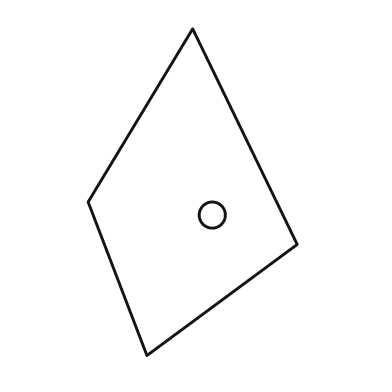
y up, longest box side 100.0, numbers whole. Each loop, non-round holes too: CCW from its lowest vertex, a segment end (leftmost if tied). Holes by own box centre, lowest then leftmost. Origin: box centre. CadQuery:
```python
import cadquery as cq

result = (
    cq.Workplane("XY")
    .moveTo(-14.0, -50.0)
    .lineTo(32.0, -16.0)
    .lineTo(0.0, 50.0)
    .lineTo(-32.0, -3.0)
    .close()
    .moveTo(6.0, -7.0)
    .circle(4.0)
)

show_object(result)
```